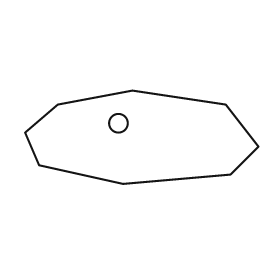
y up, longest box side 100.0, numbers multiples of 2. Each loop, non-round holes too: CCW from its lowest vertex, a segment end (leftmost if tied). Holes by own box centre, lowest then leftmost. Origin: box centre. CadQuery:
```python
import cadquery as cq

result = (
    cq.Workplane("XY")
    .moveTo(-8.0, -20.0)
    .lineTo(38.0, -16.0)
    .lineTo(50.0, -4.0)
    .lineTo(36.0, 14.0)
    .lineTo(-4.0, 20.0)
    .lineTo(-36.0, 14.0)
    .lineTo(-50.0, 2.0)
    .lineTo(-44.0, -12.0)
    .close()
    .moveTo(-10.0, 6.0)
    .circle(4.0)
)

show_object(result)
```